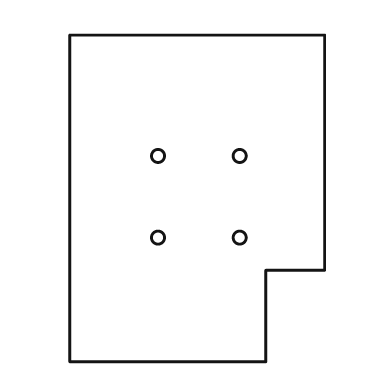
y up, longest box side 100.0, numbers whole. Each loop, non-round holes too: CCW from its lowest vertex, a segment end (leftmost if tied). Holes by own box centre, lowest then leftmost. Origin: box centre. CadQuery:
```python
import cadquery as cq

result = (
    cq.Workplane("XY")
    .moveTo(-39.0, -50.0)
    .lineTo(21.0, -50.0)
    .lineTo(21.0, -22.0)
    .lineTo(39.0, -22.0)
    .lineTo(39.0, 50.0)
    .lineTo(-39.0, 50.0)
    .close()
    .moveTo(-12.0, -12.0)
    .circle(2.0)
    .moveTo(13.0, -12.0)
    .circle(2.0)
    .moveTo(-12.0, 13.0)
    .circle(2.0)
    .moveTo(13.0, 13.0)
    .circle(2.0)
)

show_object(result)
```